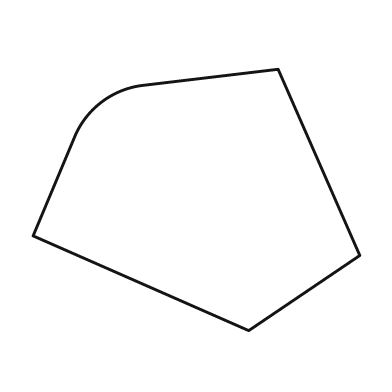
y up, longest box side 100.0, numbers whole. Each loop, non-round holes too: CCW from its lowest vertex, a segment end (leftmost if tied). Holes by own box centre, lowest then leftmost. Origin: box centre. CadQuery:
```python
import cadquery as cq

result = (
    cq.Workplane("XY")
    .moveTo(16.0, -40.0)
    .lineTo(50.0, -17.0)
    .lineTo(25.0, 40.0)
    .lineTo(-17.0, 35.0)
    .threePointArc((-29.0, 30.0), (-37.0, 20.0))
    .lineTo(-50.0, -11.0)
    .close()
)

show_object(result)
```